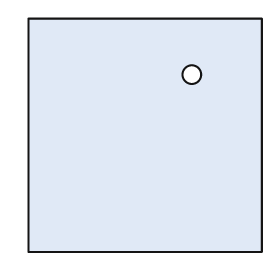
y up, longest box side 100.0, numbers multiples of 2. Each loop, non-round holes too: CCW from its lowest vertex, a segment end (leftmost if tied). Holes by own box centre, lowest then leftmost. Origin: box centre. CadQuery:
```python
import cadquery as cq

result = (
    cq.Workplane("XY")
    .moveTo(-50.0, -50.0)
    .lineTo(50.0, -50.0)
    .lineTo(50.0, 50.0)
    .lineTo(-50.0, 50.0)
    .close()
    .moveTo(20.0, 26.0)
    .circle(4.0)
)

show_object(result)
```